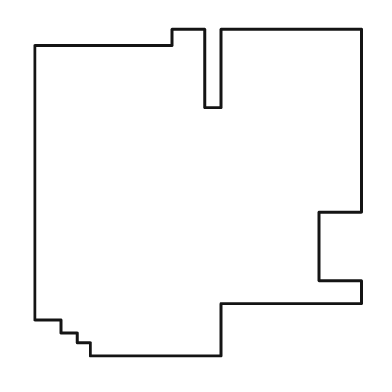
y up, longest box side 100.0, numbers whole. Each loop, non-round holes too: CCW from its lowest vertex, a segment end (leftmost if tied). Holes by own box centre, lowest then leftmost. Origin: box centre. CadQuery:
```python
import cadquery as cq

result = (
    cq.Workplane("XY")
    .moveTo(-33.0, -50.0)
    .lineTo(7.0, -50.0)
    .lineTo(7.0, -34.0)
    .lineTo(50.0, -34.0)
    .lineTo(50.0, -27.0)
    .lineTo(37.0, -27.0)
    .lineTo(37.0, -6.0)
    .lineTo(50.0, -6.0)
    .lineTo(50.0, 50.0)
    .lineTo(7.0, 50.0)
    .lineTo(7.0, 26.0)
    .lineTo(2.0, 26.0)
    .lineTo(2.0, 50.0)
    .lineTo(-8.0, 50.0)
    .lineTo(-8.0, 45.0)
    .lineTo(-50.0, 45.0)
    .lineTo(-50.0, -39.0)
    .lineTo(-42.0, -39.0)
    .lineTo(-42.0, -43.0)
    .lineTo(-37.0, -43.0)
    .lineTo(-37.0, -46.0)
    .lineTo(-33.0, -46.0)
    .close()
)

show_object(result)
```